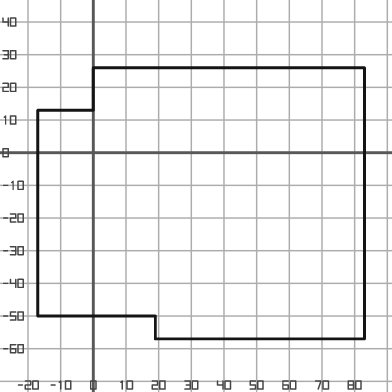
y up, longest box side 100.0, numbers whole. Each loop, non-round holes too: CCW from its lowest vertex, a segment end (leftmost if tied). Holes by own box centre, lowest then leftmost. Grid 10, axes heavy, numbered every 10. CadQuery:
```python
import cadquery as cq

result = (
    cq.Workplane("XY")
    .moveTo(19.0, -57.0)
    .lineTo(83.0, -57.0)
    .lineTo(83.0, 26.0)
    .lineTo(0.0, 26.0)
    .lineTo(0.0, 13.0)
    .lineTo(-17.0, 13.0)
    .lineTo(-17.0, -50.0)
    .lineTo(19.0, -50.0)
    .close()
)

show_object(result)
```